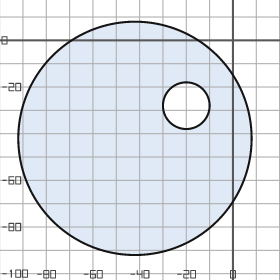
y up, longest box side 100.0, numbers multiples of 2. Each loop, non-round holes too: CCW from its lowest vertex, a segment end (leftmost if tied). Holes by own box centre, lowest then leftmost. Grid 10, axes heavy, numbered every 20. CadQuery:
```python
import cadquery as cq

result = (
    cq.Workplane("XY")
    .moveTo(-42.0, -42.0)
    .circle(50.0)
    .moveTo(-20.0, -28.0)
    .circle(10.0)
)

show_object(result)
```